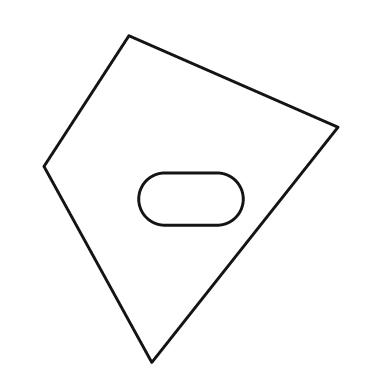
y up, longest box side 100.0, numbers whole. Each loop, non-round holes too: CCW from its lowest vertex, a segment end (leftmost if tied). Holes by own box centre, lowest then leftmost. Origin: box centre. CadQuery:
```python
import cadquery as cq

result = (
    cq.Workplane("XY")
    .moveTo(-12.0, -50.0)
    .lineTo(45.0, 22.0)
    .lineTo(-19.0, 50.0)
    .lineTo(-45.0, 10.0)
    .close()
    .moveTo(-8.0, -8.0)
    .lineTo(8.0, -8.0)
    .threePointArc((16.0, 0.0), (8.0, 8.0))
    .lineTo(-8.0, 8.0)
    .threePointArc((-16.0, 0.0), (-8.0, -8.0))
    .close()
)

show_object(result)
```